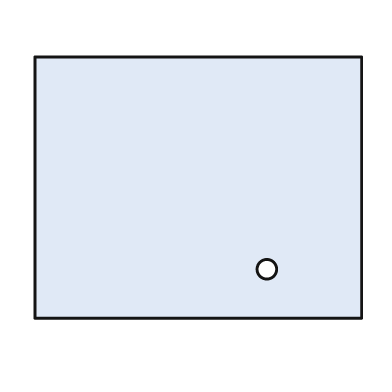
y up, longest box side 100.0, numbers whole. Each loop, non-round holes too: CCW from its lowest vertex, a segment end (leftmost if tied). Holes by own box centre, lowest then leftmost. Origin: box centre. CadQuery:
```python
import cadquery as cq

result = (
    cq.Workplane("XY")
    .moveTo(-50.0, -40.0)
    .lineTo(50.0, -40.0)
    .lineTo(50.0, 40.0)
    .lineTo(-50.0, 40.0)
    .close()
    .moveTo(21.0, -25.0)
    .circle(3.0)
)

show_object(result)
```